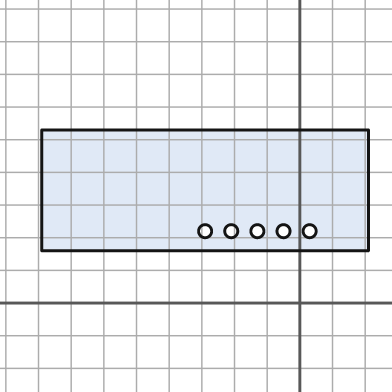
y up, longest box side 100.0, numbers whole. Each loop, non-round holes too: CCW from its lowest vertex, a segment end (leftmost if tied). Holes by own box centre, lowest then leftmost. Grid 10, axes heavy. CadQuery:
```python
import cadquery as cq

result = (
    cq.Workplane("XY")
    .moveTo(-79.0, 16.0)
    .lineTo(21.0, 16.0)
    .lineTo(21.0, 53.0)
    .lineTo(-79.0, 53.0)
    .close()
    .moveTo(-29.0, 22.0)
    .circle(2.0)
    .moveTo(-21.0, 22.0)
    .circle(2.0)
    .moveTo(-13.0, 22.0)
    .circle(2.0)
    .moveTo(-5.0, 22.0)
    .circle(2.0)
    .moveTo(3.0, 22.0)
    .circle(2.0)
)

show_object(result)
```